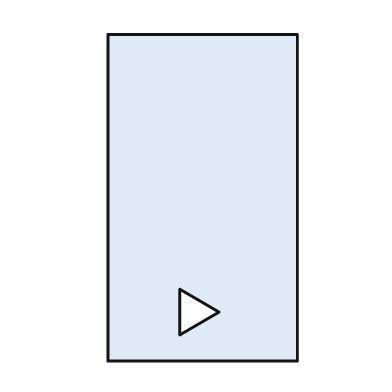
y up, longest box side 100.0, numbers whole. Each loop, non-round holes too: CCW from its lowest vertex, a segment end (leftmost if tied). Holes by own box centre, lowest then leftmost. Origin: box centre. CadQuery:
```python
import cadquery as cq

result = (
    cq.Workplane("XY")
    .moveTo(-29.0, -50.0)
    .lineTo(29.0, -50.0)
    .lineTo(29.0, 50.0)
    .lineTo(-29.0, 50.0)
    .close()
    .moveTo(-7.0, -42.0)
    .lineTo(5.0, -35.0)
    .lineTo(-7.0, -28.0)
    .close()
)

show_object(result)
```